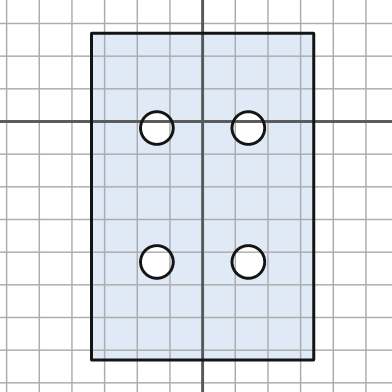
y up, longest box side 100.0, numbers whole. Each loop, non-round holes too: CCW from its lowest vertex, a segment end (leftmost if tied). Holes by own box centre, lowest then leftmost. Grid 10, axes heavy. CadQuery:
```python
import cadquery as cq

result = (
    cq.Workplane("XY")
    .moveTo(-34.0, -73.0)
    .lineTo(34.0, -73.0)
    .lineTo(34.0, 27.0)
    .lineTo(-34.0, 27.0)
    .close()
    .moveTo(-14.0, -43.0)
    .circle(5.0)
    .moveTo(14.0, -43.0)
    .circle(5.0)
    .moveTo(-14.0, -2.0)
    .circle(5.0)
    .moveTo(14.0, -2.0)
    .circle(5.0)
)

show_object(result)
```